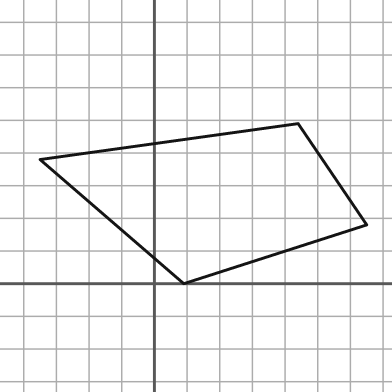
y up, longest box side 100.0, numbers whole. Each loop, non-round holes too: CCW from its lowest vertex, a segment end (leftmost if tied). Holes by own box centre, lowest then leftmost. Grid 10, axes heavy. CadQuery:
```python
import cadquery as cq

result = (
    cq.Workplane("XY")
    .moveTo(9.0, 0.0)
    .lineTo(65.0, 18.0)
    .lineTo(44.0, 49.0)
    .lineTo(-35.0, 38.0)
    .close()
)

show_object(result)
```